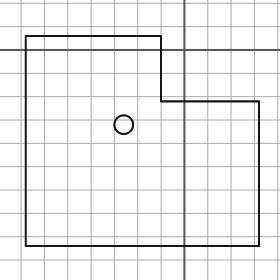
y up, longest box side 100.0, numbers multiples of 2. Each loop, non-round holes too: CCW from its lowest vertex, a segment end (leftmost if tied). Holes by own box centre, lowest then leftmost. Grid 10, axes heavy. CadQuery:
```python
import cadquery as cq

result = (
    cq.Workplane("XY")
    .moveTo(-68.0, -84.0)
    .lineTo(32.0, -84.0)
    .lineTo(32.0, -22.0)
    .lineTo(-10.0, -22.0)
    .lineTo(-10.0, 6.0)
    .lineTo(-68.0, 6.0)
    .close()
    .moveTo(-26.0, -32.0)
    .circle(4.0)
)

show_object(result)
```